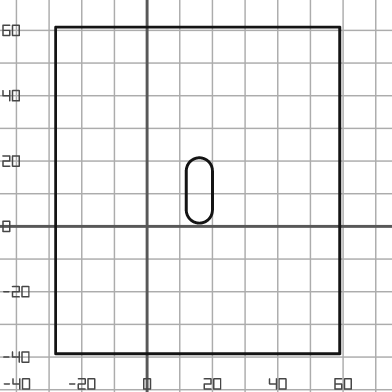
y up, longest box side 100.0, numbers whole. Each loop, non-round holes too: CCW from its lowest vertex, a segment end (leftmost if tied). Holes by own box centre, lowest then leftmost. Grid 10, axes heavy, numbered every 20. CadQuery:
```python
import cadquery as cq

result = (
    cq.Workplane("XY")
    .moveTo(-28.0, -39.0)
    .lineTo(59.0, -39.0)
    .lineTo(59.0, 61.0)
    .lineTo(-28.0, 61.0)
    .close()
    .moveTo(12.0, 5.0)
    .threePointArc((16.0, 1.0), (20.0, 5.0))
    .lineTo(20.0, 17.0)
    .threePointArc((16.0, 21.0), (12.0, 17.0))
    .close()
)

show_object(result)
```